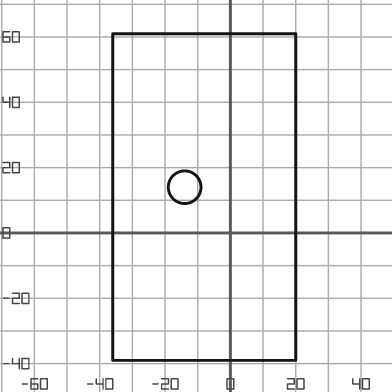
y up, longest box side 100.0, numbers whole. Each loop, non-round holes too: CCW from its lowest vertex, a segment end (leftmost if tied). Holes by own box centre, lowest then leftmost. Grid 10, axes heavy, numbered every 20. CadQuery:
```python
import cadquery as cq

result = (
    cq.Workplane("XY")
    .moveTo(-36.0, -39.0)
    .lineTo(20.0, -39.0)
    .lineTo(20.0, 61.0)
    .lineTo(-36.0, 61.0)
    .close()
    .moveTo(-14.0, 14.0)
    .circle(5.0)
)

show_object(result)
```